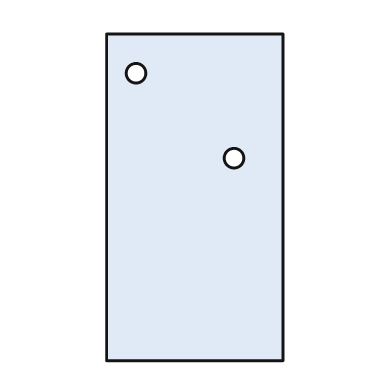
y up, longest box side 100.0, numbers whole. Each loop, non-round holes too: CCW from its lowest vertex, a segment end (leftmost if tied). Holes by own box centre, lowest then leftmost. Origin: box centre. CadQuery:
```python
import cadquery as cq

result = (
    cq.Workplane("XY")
    .moveTo(-27.0, -50.0)
    .lineTo(27.0, -50.0)
    .lineTo(27.0, 50.0)
    .lineTo(-27.0, 50.0)
    .close()
    .moveTo(12.0, 12.0)
    .circle(3.0)
    .moveTo(-18.0, 38.0)
    .circle(3.0)
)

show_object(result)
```